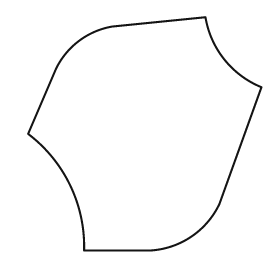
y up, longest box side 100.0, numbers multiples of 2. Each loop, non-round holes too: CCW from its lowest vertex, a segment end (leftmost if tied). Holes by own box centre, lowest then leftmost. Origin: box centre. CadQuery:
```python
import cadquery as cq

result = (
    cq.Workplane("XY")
    .moveTo(-26.0, -50.0)
    .lineTo(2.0, -50.0)
    .threePointArc((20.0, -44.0), (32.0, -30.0))
    .lineTo(50.0, 20.0)
    .threePointArc((34.0, 32.0), (26.0, 50.0))
    .lineTo(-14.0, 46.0)
    .threePointArc((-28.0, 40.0), (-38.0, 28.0))
    .lineTo(-50.0, 0.0)
    .threePointArc((-32.0, -22.0), (-26.0, -50.0))
    .close()
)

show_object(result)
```